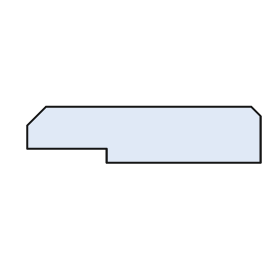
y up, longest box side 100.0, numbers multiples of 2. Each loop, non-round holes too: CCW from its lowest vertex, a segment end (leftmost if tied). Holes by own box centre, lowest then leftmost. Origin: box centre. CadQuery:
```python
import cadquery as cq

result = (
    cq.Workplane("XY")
    .moveTo(-16.0, -12.0)
    .lineTo(50.0, -12.0)
    .lineTo(50.0, 8.0)
    .lineTo(46.0, 12.0)
    .lineTo(-42.0, 12.0)
    .lineTo(-50.0, 4.0)
    .lineTo(-50.0, -6.0)
    .lineTo(-16.0, -6.0)
    .close()
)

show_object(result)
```